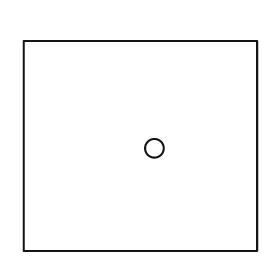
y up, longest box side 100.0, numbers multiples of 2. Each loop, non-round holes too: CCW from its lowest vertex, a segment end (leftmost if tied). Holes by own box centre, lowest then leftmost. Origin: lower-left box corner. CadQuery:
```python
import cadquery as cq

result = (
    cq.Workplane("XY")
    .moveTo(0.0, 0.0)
    .lineTo(100.0, 0.0)
    .lineTo(100.0, 90.0)
    .lineTo(0.0, 90.0)
    .close()
    .moveTo(56.0, 44.0)
    .circle(4.0)
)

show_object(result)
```